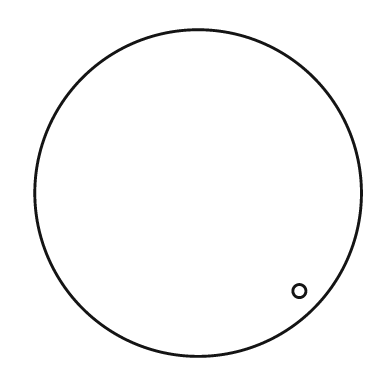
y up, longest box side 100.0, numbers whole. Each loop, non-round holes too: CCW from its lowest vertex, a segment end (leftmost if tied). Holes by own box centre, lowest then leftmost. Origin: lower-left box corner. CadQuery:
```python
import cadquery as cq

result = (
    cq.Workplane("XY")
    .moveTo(50.0, 50.0)
    .circle(50.0)
    .moveTo(81.0, 20.0)
    .circle(2.0)
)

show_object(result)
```